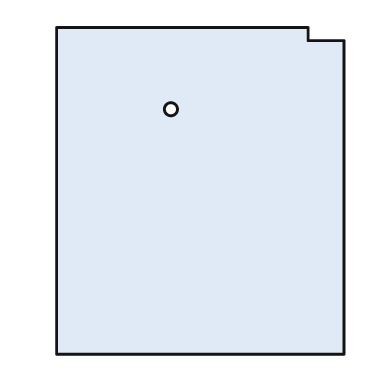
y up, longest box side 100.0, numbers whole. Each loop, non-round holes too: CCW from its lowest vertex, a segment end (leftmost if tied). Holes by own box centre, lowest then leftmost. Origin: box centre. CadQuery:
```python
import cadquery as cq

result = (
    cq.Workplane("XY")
    .moveTo(-44.0, -50.0)
    .lineTo(44.0, -50.0)
    .lineTo(44.0, 46.0)
    .lineTo(33.0, 46.0)
    .lineTo(33.0, 50.0)
    .lineTo(-44.0, 50.0)
    .close()
    .moveTo(-9.0, 25.0)
    .circle(2.0)
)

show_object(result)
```